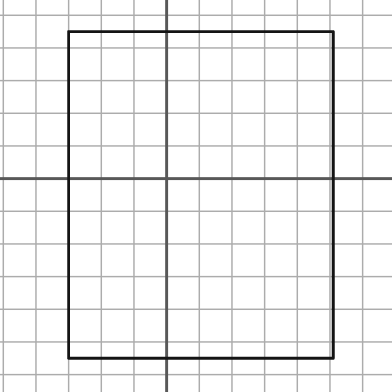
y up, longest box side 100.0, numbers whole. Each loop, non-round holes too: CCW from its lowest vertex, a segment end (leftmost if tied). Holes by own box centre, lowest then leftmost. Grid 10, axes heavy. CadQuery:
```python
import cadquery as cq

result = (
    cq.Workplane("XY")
    .moveTo(-30.0, -55.0)
    .lineTo(51.0, -55.0)
    .lineTo(51.0, 45.0)
    .lineTo(-30.0, 45.0)
    .close()
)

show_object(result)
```